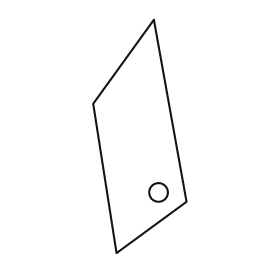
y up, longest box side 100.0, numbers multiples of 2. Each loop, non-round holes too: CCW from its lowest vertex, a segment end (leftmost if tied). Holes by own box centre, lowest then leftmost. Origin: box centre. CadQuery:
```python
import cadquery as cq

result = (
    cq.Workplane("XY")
    .moveTo(-10.0, -50.0)
    .lineTo(20.0, -28.0)
    .lineTo(6.0, 50.0)
    .lineTo(-20.0, 14.0)
    .close()
    .moveTo(8.0, -24.0)
    .circle(4.0)
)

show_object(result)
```